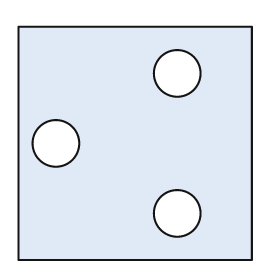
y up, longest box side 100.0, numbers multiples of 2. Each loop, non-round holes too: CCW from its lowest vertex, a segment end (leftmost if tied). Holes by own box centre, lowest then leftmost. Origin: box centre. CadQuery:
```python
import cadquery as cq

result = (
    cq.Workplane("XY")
    .moveTo(-50.0, -50.0)
    .lineTo(50.0, -50.0)
    .lineTo(50.0, 50.0)
    .lineTo(-50.0, 50.0)
    .close()
    .moveTo(18.0, -30.0)
    .circle(10.0)
    .moveTo(-34.0, 0.0)
    .circle(10.0)
    .moveTo(18.0, 30.0)
    .circle(10.0)
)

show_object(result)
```